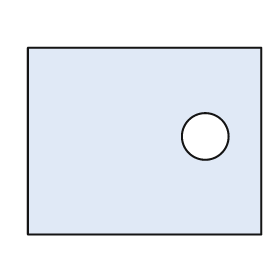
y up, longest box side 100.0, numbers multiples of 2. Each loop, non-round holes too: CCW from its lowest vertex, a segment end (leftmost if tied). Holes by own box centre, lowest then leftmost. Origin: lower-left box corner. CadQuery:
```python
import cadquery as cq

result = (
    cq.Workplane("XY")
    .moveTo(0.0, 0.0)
    .lineTo(100.0, 0.0)
    .lineTo(100.0, 80.0)
    .lineTo(0.0, 80.0)
    .close()
    .moveTo(76.0, 42.0)
    .circle(10.0)
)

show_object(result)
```